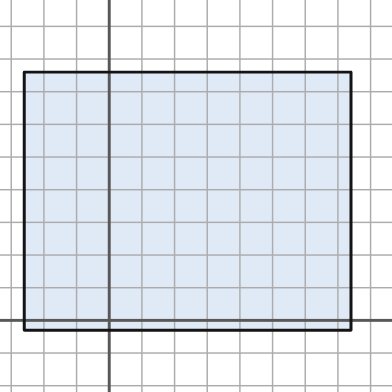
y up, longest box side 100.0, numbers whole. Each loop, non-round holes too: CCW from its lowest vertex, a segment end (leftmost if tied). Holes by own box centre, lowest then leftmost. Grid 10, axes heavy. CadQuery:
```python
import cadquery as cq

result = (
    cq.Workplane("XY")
    .moveTo(-26.0, -3.0)
    .lineTo(74.0, -3.0)
    .lineTo(74.0, 76.0)
    .lineTo(-26.0, 76.0)
    .close()
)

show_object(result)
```